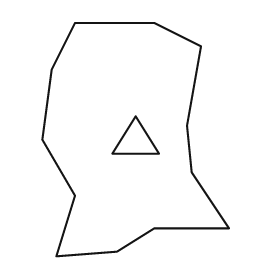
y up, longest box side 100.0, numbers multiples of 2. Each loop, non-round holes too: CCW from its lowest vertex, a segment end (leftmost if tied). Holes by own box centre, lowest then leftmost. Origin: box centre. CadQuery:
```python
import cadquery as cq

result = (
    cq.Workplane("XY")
    .moveTo(-34.0, -50.0)
    .lineTo(-8.0, -48.0)
    .lineTo(8.0, -38.0)
    .lineTo(40.0, -38.0)
    .lineTo(24.0, -14.0)
    .lineTo(22.0, 6.0)
    .lineTo(28.0, 40.0)
    .lineTo(8.0, 50.0)
    .lineTo(-26.0, 50.0)
    .lineTo(-36.0, 30.0)
    .lineTo(-40.0, 0.0)
    .lineTo(-26.0, -24.0)
    .close()
    .moveTo(-10.0, -6.0)
    .lineTo(10.0, -6.0)
    .lineTo(0.0, 10.0)
    .close()
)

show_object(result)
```